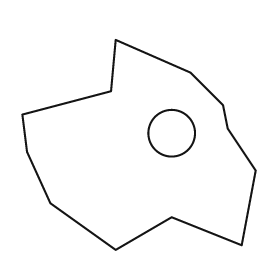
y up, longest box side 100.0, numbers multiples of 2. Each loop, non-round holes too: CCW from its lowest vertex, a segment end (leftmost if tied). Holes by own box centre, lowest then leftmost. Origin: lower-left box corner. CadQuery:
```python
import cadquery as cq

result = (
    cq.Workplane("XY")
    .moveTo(40.0, 0.0)
    .lineTo(64.0, 14.0)
    .lineTo(94.0, 2.0)
    .lineTo(100.0, 34.0)
    .lineTo(88.0, 52.0)
    .lineTo(86.0, 62.0)
    .lineTo(72.0, 76.0)
    .lineTo(40.0, 90.0)
    .lineTo(38.0, 68.0)
    .lineTo(0.0, 58.0)
    .lineTo(2.0, 42.0)
    .lineTo(12.0, 20.0)
    .close()
    .moveTo(64.0, 50.0)
    .circle(10.0)
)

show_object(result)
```